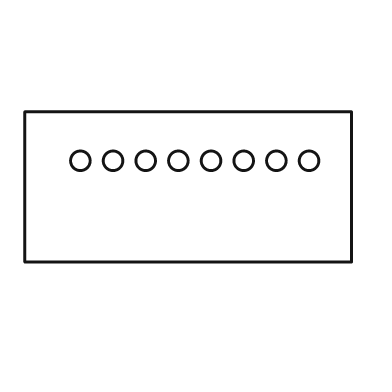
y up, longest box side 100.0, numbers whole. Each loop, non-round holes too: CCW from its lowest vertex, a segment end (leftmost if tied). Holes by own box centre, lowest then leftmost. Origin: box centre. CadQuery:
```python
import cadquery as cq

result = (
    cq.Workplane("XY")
    .moveTo(-50.0, -23.0)
    .lineTo(50.0, -23.0)
    .lineTo(50.0, 23.0)
    .lineTo(-50.0, 23.0)
    .close()
    .moveTo(-33.0, 8.0)
    .circle(3.0)
    .moveTo(-23.0, 8.0)
    .circle(3.0)
    .moveTo(-13.0, 8.0)
    .circle(3.0)
    .moveTo(-3.0, 8.0)
    .circle(3.0)
    .moveTo(7.0, 8.0)
    .circle(3.0)
    .moveTo(17.0, 8.0)
    .circle(3.0)
    .moveTo(27.0, 8.0)
    .circle(3.0)
    .moveTo(37.0, 8.0)
    .circle(3.0)
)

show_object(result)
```